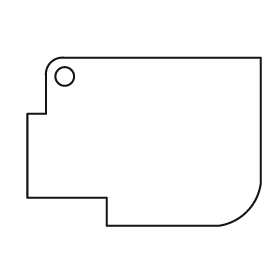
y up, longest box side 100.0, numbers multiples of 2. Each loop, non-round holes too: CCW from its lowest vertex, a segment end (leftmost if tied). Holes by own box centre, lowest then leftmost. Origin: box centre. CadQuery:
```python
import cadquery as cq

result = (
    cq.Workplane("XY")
    .moveTo(-16.0, -36.0)
    .lineTo(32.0, -36.0)
    .threePointArc((44.0, -30.0), (50.0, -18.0))
    .lineTo(50.0, 36.0)
    .lineTo(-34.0, 36.0)
    .threePointArc((-40.0, 34.0), (-42.0, 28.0))
    .lineTo(-42.0, 12.0)
    .lineTo(-50.0, 12.0)
    .lineTo(-50.0, -24.0)
    .lineTo(-16.0, -24.0)
    .close()
    .moveTo(-34.0, 28.0)
    .circle(4.0)
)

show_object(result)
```